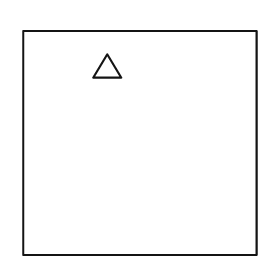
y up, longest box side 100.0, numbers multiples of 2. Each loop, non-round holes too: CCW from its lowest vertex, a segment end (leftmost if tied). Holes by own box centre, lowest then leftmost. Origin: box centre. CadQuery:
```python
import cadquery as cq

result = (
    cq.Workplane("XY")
    .moveTo(-50.0, -48.0)
    .lineTo(50.0, -48.0)
    .lineTo(50.0, 48.0)
    .lineTo(-50.0, 48.0)
    .close()
    .moveTo(-20.0, 28.0)
    .lineTo(-8.0, 28.0)
    .lineTo(-14.0, 38.0)
    .close()
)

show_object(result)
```